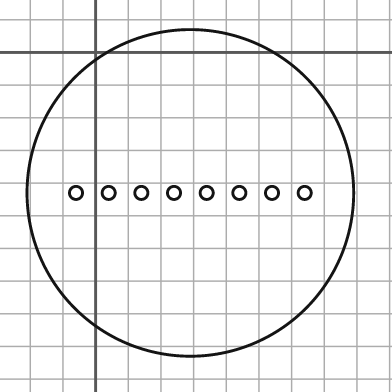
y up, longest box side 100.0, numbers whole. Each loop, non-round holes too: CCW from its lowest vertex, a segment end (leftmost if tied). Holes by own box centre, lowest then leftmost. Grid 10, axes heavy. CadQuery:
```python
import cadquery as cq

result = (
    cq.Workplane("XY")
    .moveTo(29.0, -43.0)
    .circle(50.0)
    .moveTo(-6.0, -43.0)
    .circle(2.0)
    .moveTo(4.0, -43.0)
    .circle(2.0)
    .moveTo(14.0, -43.0)
    .circle(2.0)
    .moveTo(24.0, -43.0)
    .circle(2.0)
    .moveTo(34.0, -43.0)
    .circle(2.0)
    .moveTo(44.0, -43.0)
    .circle(2.0)
    .moveTo(54.0, -43.0)
    .circle(2.0)
    .moveTo(64.0, -43.0)
    .circle(2.0)
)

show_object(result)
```